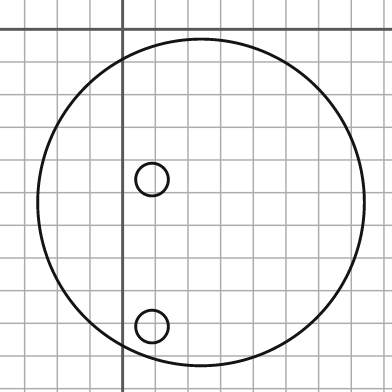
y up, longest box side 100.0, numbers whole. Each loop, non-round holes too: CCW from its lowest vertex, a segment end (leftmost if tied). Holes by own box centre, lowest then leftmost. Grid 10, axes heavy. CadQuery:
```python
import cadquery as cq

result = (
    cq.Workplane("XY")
    .moveTo(24.0, -53.0)
    .circle(50.0)
    .moveTo(9.0, -91.0)
    .circle(5.0)
    .moveTo(9.0, -46.0)
    .circle(5.0)
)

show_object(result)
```